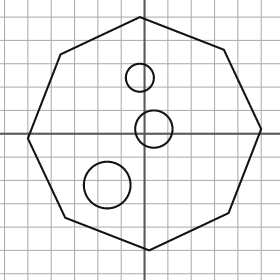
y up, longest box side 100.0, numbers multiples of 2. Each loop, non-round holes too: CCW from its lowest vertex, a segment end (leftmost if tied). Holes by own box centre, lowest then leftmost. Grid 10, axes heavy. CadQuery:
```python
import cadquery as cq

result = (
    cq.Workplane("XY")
    .moveTo(2.0, -50.0)
    .lineTo(36.0, -34.0)
    .lineTo(50.0, 2.0)
    .lineTo(34.0, 36.0)
    .lineTo(-2.0, 50.0)
    .lineTo(-36.0, 34.0)
    .lineTo(-50.0, -2.0)
    .lineTo(-34.0, -36.0)
    .close()
    .moveTo(-16.0, -22.0)
    .circle(10.0)
    .moveTo(4.0, 2.0)
    .circle(8.0)
    .moveTo(-2.0, 24.0)
    .circle(6.0)
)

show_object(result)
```